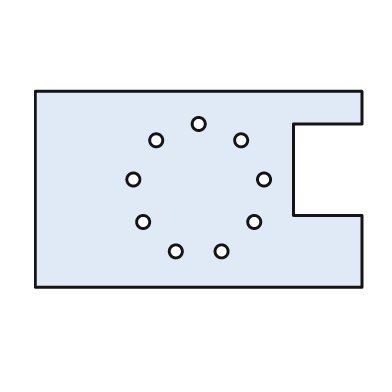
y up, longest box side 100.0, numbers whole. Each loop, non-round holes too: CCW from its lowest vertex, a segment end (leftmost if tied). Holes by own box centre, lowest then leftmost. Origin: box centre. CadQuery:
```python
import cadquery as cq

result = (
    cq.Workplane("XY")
    .moveTo(-50.0, -30.0)
    .lineTo(50.0, -30.0)
    .lineTo(50.0, -8.0)
    .lineTo(29.0, -8.0)
    .lineTo(29.0, 20.0)
    .lineTo(50.0, 20.0)
    .lineTo(50.0, 30.0)
    .lineTo(-50.0, 30.0)
    .close()
    .moveTo(-7.0, -19.0)
    .circle(2.0)
    .moveTo(7.0, -19.0)
    .circle(2.0)
    .moveTo(-17.0, -10.0)
    .circle(2.0)
    .moveTo(17.0, -10.0)
    .circle(2.0)
    .moveTo(-20.0, 3.0)
    .circle(2.0)
    .moveTo(20.0, 3.0)
    .circle(2.0)
    .moveTo(-13.0, 15.0)
    .circle(2.0)
    .moveTo(13.0, 15.0)
    .circle(2.0)
    .moveTo(0.0, 20.0)
    .circle(2.0)
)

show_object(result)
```